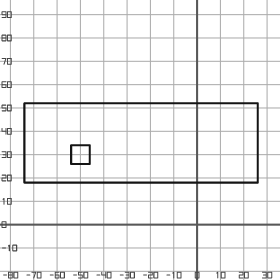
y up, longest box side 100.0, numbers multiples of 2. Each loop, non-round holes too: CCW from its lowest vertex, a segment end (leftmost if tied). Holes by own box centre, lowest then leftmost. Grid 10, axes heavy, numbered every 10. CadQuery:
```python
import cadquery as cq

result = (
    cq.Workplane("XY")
    .moveTo(-74.0, 18.0)
    .lineTo(26.0, 18.0)
    .lineTo(26.0, 52.0)
    .lineTo(-74.0, 52.0)
    .close()
    .moveTo(-54.0, 26.0)
    .lineTo(-46.0, 26.0)
    .lineTo(-46.0, 34.0)
    .lineTo(-54.0, 34.0)
    .close()
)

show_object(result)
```